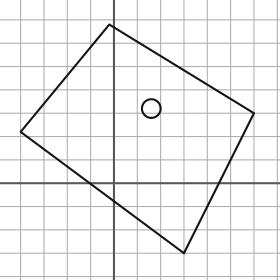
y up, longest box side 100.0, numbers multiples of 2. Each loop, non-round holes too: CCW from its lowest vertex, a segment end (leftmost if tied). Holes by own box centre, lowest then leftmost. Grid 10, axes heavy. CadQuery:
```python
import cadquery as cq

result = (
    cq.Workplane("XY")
    .moveTo(30.0, -30.0)
    .lineTo(60.0, 30.0)
    .lineTo(-2.0, 68.0)
    .lineTo(-40.0, 22.0)
    .close()
    .moveTo(16.0, 32.0)
    .circle(4.0)
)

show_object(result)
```